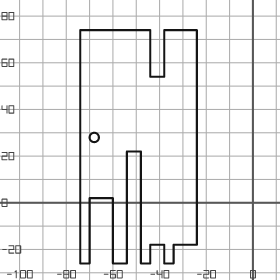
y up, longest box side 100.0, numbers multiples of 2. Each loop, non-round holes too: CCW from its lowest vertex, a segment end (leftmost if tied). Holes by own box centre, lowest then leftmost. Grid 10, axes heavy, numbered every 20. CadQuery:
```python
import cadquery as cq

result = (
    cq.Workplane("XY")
    .moveTo(-74.0, -26.0)
    .lineTo(-70.0, -26.0)
    .lineTo(-70.0, 2.0)
    .lineTo(-60.0, 2.0)
    .lineTo(-60.0, -26.0)
    .lineTo(-54.0, -26.0)
    .lineTo(-54.0, 22.0)
    .lineTo(-48.0, 22.0)
    .lineTo(-48.0, -26.0)
    .lineTo(-44.0, -26.0)
    .lineTo(-44.0, -18.0)
    .lineTo(-38.0, -18.0)
    .lineTo(-38.0, -26.0)
    .lineTo(-34.0, -26.0)
    .lineTo(-34.0, -18.0)
    .lineTo(-24.0, -18.0)
    .lineTo(-24.0, 74.0)
    .lineTo(-38.0, 74.0)
    .lineTo(-38.0, 54.0)
    .lineTo(-44.0, 54.0)
    .lineTo(-44.0, 74.0)
    .lineTo(-74.0, 74.0)
    .close()
    .moveTo(-68.0, 28.0)
    .circle(2.0)
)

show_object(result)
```